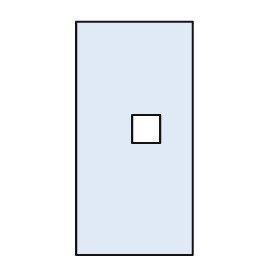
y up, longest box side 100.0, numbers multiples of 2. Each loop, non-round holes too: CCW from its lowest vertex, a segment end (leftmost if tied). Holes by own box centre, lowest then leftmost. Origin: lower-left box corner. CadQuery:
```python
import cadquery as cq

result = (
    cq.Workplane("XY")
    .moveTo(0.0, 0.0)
    .lineTo(50.0, 0.0)
    .lineTo(50.0, 100.0)
    .lineTo(0.0, 100.0)
    .close()
    .moveTo(24.0, 48.0)
    .lineTo(36.0, 48.0)
    .lineTo(36.0, 60.0)
    .lineTo(24.0, 60.0)
    .close()
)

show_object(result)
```